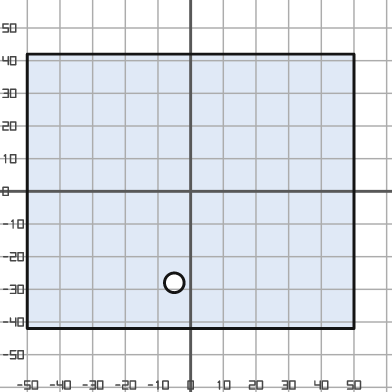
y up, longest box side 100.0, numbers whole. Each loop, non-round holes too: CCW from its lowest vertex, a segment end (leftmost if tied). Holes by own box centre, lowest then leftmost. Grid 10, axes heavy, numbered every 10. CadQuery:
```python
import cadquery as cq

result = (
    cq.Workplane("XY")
    .moveTo(-50.0, -42.0)
    .lineTo(50.0, -42.0)
    .lineTo(50.0, 42.0)
    .lineTo(-50.0, 42.0)
    .close()
    .moveTo(-5.0, -28.0)
    .circle(3.0)
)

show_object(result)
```